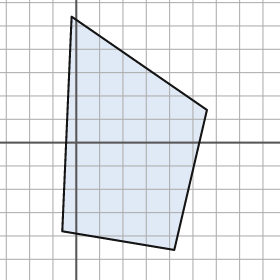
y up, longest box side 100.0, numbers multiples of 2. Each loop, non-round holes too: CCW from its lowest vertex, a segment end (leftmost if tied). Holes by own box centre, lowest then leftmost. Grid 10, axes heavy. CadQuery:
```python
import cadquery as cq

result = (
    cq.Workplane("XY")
    .moveTo(42.0, -46.0)
    .lineTo(56.0, 14.0)
    .lineTo(-2.0, 54.0)
    .lineTo(-6.0, -38.0)
    .close()
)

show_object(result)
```